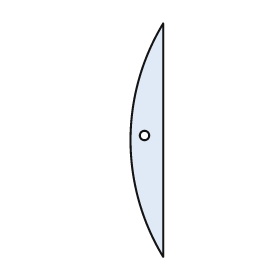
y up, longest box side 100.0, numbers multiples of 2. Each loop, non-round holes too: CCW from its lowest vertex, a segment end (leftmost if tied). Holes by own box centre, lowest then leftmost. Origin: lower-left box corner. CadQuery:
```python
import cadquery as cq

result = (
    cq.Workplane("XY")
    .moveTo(14.0, 0.0)
    .lineTo(14.0, 100.0)
    .threePointArc((0.0, 50.0), (14.0, 0.0))
    .close()
    .moveTo(6.0, 52.0)
    .circle(2.0)
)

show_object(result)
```